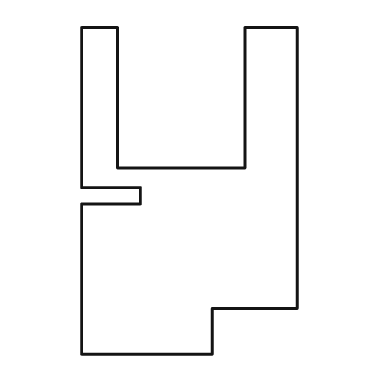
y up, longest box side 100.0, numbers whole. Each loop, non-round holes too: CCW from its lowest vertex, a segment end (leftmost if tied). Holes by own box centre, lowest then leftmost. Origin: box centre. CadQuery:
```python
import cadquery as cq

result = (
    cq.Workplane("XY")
    .moveTo(-33.0, -50.0)
    .lineTo(7.0, -50.0)
    .lineTo(7.0, -36.0)
    .lineTo(33.0, -36.0)
    .lineTo(33.0, 50.0)
    .lineTo(17.0, 50.0)
    .lineTo(17.0, 7.0)
    .lineTo(-22.0, 7.0)
    .lineTo(-22.0, 50.0)
    .lineTo(-33.0, 50.0)
    .lineTo(-33.0, 1.0)
    .lineTo(-15.0, 1.0)
    .lineTo(-15.0, -4.0)
    .lineTo(-33.0, -4.0)
    .close()
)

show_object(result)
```